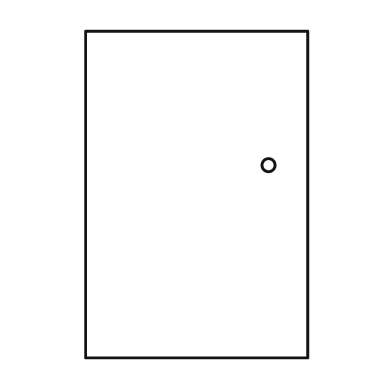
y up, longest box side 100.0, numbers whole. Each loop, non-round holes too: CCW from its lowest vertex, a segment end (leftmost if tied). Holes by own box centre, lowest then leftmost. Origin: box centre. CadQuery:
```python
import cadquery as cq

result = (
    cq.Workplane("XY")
    .moveTo(-34.0, -50.0)
    .lineTo(34.0, -50.0)
    .lineTo(34.0, 50.0)
    .lineTo(-34.0, 50.0)
    .close()
    .moveTo(22.0, 9.0)
    .circle(2.0)
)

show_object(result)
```